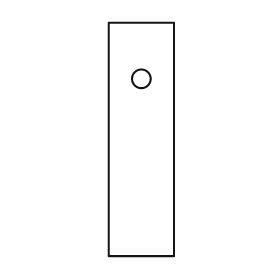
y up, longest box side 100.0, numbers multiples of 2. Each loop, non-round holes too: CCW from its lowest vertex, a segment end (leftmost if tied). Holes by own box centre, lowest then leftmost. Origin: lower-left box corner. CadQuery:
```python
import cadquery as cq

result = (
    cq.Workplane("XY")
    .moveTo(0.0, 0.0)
    .lineTo(28.0, 0.0)
    .lineTo(28.0, 100.0)
    .lineTo(0.0, 100.0)
    .close()
    .moveTo(14.0, 76.0)
    .circle(4.0)
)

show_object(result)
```